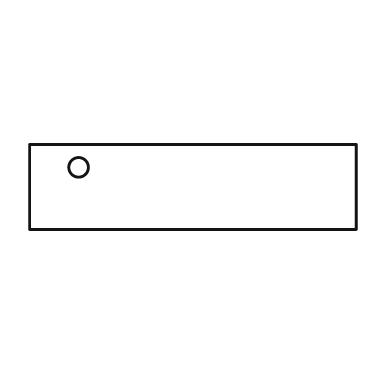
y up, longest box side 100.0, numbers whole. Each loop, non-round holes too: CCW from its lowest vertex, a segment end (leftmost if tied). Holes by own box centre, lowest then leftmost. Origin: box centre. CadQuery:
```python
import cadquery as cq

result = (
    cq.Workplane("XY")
    .moveTo(-50.0, -13.0)
    .lineTo(50.0, -13.0)
    .lineTo(50.0, 13.0)
    .lineTo(-50.0, 13.0)
    .close()
    .moveTo(-35.0, 6.0)
    .circle(3.0)
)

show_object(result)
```